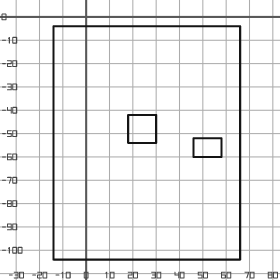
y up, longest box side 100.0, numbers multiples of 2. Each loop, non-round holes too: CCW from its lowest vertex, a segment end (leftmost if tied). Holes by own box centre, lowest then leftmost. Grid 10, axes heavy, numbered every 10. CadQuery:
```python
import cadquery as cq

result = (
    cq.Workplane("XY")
    .moveTo(-14.0, -104.0)
    .lineTo(66.0, -104.0)
    .lineTo(66.0, -4.0)
    .lineTo(-14.0, -4.0)
    .close()
    .moveTo(46.0, -60.0)
    .lineTo(58.0, -60.0)
    .lineTo(58.0, -52.0)
    .lineTo(46.0, -52.0)
    .close()
    .moveTo(18.0, -54.0)
    .lineTo(30.0, -54.0)
    .lineTo(30.0, -42.0)
    .lineTo(18.0, -42.0)
    .close()
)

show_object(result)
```